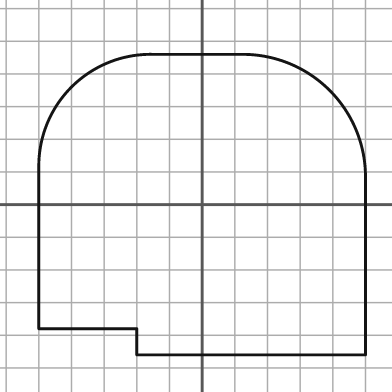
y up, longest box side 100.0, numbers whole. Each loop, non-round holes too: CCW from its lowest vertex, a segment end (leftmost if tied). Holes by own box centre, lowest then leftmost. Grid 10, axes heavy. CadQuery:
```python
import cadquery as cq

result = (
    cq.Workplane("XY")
    .moveTo(-20.0, -46.0)
    .lineTo(50.0, -46.0)
    .lineTo(50.0, 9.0)
    .threePointArc((39.0, 35.0), (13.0, 46.0))
    .lineTo(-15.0, 46.0)
    .threePointArc((-40.0, 36.0), (-50.0, 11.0))
    .lineTo(-50.0, -38.0)
    .lineTo(-20.0, -38.0)
    .close()
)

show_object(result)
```